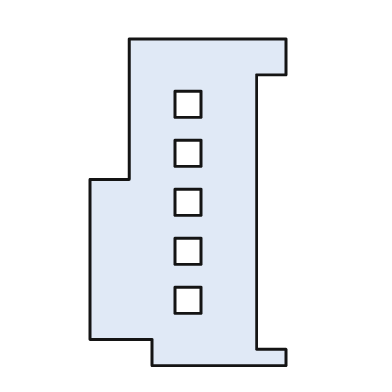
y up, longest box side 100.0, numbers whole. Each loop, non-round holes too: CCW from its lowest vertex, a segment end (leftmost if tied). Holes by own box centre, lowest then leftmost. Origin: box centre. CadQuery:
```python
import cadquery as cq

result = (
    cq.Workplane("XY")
    .moveTo(-11.0, -50.0)
    .lineTo(30.0, -50.0)
    .lineTo(30.0, -45.0)
    .lineTo(21.0, -45.0)
    .lineTo(21.0, 39.0)
    .lineTo(30.0, 39.0)
    .lineTo(30.0, 50.0)
    .lineTo(-18.0, 50.0)
    .lineTo(-18.0, 7.0)
    .lineTo(-30.0, 7.0)
    .lineTo(-30.0, -42.0)
    .lineTo(-11.0, -42.0)
    .close()
    .moveTo(-4.0, -34.0)
    .lineTo(4.0, -34.0)
    .lineTo(4.0, -26.0)
    .lineTo(-4.0, -26.0)
    .close()
    .moveTo(-4.0, -19.0)
    .lineTo(4.0, -19.0)
    .lineTo(4.0, -11.0)
    .lineTo(-4.0, -11.0)
    .close()
    .moveTo(-4.0, -4.0)
    .lineTo(4.0, -4.0)
    .lineTo(4.0, 4.0)
    .lineTo(-4.0, 4.0)
    .close()
    .moveTo(-4.0, 11.0)
    .lineTo(4.0, 11.0)
    .lineTo(4.0, 19.0)
    .lineTo(-4.0, 19.0)
    .close()
    .moveTo(-4.0, 26.0)
    .lineTo(4.0, 26.0)
    .lineTo(4.0, 34.0)
    .lineTo(-4.0, 34.0)
    .close()
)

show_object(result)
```